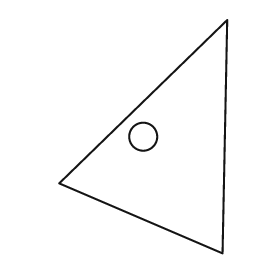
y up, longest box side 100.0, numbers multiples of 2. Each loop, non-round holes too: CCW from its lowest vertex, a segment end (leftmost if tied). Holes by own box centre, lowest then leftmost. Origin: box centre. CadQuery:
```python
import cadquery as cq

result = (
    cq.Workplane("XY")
    .moveTo(34.0, -50.0)
    .lineTo(36.0, 50.0)
    .lineTo(-36.0, -20.0)
    .close()
    .moveTo(0.0, 0.0)
    .circle(6.0)
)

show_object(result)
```